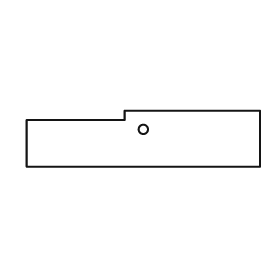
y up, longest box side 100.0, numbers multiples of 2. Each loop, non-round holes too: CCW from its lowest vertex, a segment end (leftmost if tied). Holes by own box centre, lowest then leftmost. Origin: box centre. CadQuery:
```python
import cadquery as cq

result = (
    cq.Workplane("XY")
    .moveTo(-50.0, -12.0)
    .lineTo(50.0, -12.0)
    .lineTo(50.0, 12.0)
    .lineTo(-8.0, 12.0)
    .lineTo(-8.0, 8.0)
    .lineTo(-50.0, 8.0)
    .close()
    .moveTo(0.0, 4.0)
    .circle(2.0)
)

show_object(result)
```